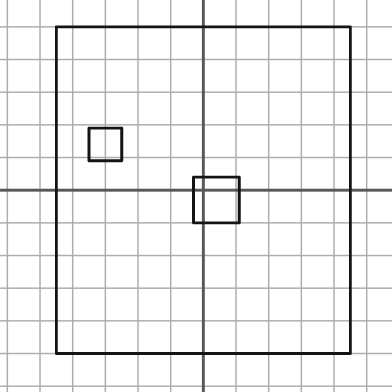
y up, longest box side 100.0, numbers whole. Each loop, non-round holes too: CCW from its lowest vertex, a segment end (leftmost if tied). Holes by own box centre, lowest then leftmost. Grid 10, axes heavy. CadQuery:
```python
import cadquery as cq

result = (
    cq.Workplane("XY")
    .moveTo(-45.0, -50.0)
    .lineTo(45.0, -50.0)
    .lineTo(45.0, 50.0)
    .lineTo(-45.0, 50.0)
    .close()
    .moveTo(-3.0, -10.0)
    .lineTo(11.0, -10.0)
    .lineTo(11.0, 4.0)
    .lineTo(-3.0, 4.0)
    .close()
    .moveTo(-35.0, 9.0)
    .lineTo(-25.0, 9.0)
    .lineTo(-25.0, 19.0)
    .lineTo(-35.0, 19.0)
    .close()
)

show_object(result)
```